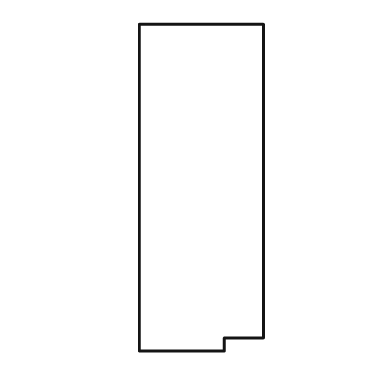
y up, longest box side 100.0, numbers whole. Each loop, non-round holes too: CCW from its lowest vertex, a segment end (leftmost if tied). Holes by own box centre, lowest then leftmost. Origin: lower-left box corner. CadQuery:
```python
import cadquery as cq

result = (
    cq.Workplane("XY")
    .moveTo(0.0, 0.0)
    .lineTo(26.0, 0.0)
    .lineTo(26.0, 4.0)
    .lineTo(38.0, 4.0)
    .lineTo(38.0, 100.0)
    .lineTo(0.0, 100.0)
    .close()
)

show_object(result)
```